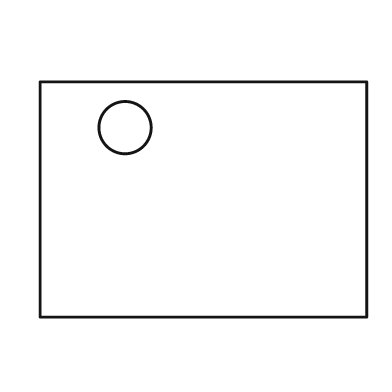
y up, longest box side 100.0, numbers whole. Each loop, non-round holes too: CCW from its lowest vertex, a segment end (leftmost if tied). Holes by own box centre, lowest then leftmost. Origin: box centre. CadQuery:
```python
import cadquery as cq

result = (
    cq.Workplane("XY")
    .moveTo(-50.0, -36.0)
    .lineTo(50.0, -36.0)
    .lineTo(50.0, 36.0)
    .lineTo(-50.0, 36.0)
    .close()
    .moveTo(-24.0, 22.0)
    .circle(8.0)
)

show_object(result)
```